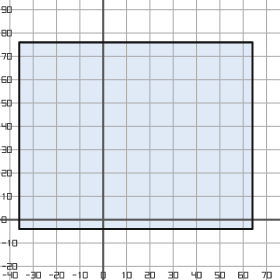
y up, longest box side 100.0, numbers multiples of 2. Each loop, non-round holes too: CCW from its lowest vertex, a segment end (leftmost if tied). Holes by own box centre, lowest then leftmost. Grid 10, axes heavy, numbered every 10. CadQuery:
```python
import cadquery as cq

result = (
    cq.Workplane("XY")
    .moveTo(-36.0, -4.0)
    .lineTo(64.0, -4.0)
    .lineTo(64.0, 76.0)
    .lineTo(-36.0, 76.0)
    .close()
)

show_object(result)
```